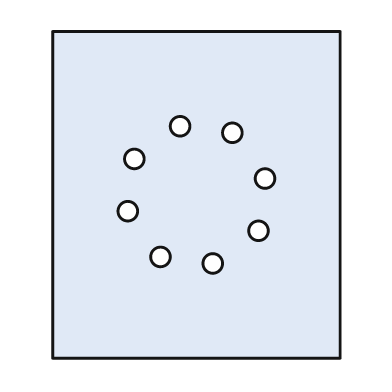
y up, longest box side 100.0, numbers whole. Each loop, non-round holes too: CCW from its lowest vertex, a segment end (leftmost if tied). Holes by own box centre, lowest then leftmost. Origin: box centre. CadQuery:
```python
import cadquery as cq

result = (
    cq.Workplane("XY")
    .moveTo(-44.0, -50.0)
    .lineTo(44.0, -50.0)
    .lineTo(44.0, 50.0)
    .lineTo(-44.0, 50.0)
    .close()
    .moveTo(5.0, -21.0)
    .circle(3.0)
    .moveTo(-11.0, -19.0)
    .circle(3.0)
    .moveTo(19.0, -11.0)
    .circle(3.0)
    .moveTo(-21.0, -5.0)
    .circle(3.0)
    .moveTo(21.0, 5.0)
    .circle(3.0)
    .moveTo(-19.0, 11.0)
    .circle(3.0)
    .moveTo(11.0, 19.0)
    .circle(3.0)
    .moveTo(-5.0, 21.0)
    .circle(3.0)
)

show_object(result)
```